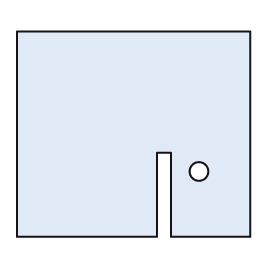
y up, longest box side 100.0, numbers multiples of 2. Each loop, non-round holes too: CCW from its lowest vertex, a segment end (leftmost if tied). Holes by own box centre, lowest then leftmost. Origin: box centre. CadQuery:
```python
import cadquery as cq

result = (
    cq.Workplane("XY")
    .moveTo(-50.0, -44.0)
    .lineTo(10.0, -44.0)
    .lineTo(10.0, -8.0)
    .lineTo(16.0, -8.0)
    .lineTo(16.0, -44.0)
    .lineTo(50.0, -44.0)
    .lineTo(50.0, 44.0)
    .lineTo(-50.0, 44.0)
    .close()
    .moveTo(28.0, -16.0)
    .circle(4.0)
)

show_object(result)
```